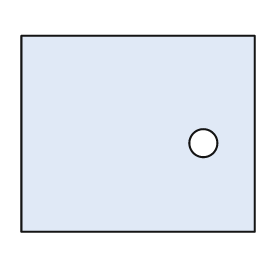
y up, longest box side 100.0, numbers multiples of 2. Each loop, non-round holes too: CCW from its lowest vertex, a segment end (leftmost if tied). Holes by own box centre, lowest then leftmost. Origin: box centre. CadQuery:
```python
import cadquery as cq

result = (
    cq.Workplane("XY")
    .moveTo(-50.0, -42.0)
    .lineTo(50.0, -42.0)
    .lineTo(50.0, 42.0)
    .lineTo(-50.0, 42.0)
    .close()
    .moveTo(28.0, -4.0)
    .circle(6.0)
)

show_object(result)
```